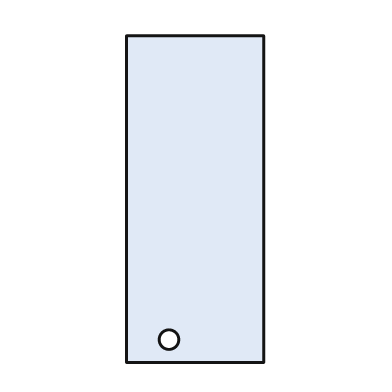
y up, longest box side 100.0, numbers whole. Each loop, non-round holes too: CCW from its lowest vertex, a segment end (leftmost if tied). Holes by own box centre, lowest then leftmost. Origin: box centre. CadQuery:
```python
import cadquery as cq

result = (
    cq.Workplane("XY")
    .moveTo(-21.0, -50.0)
    .lineTo(21.0, -50.0)
    .lineTo(21.0, 50.0)
    .lineTo(-21.0, 50.0)
    .close()
    .moveTo(-8.0, -43.0)
    .circle(3.0)
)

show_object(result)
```